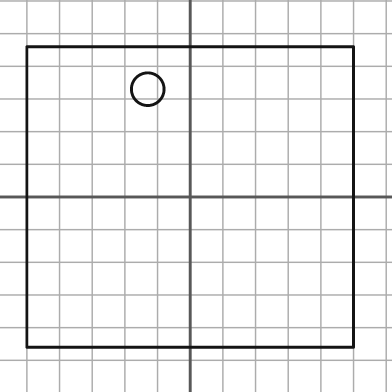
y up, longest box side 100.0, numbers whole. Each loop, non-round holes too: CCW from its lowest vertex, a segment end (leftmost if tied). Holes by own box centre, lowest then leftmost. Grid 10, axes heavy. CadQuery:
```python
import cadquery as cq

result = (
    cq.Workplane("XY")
    .moveTo(-50.0, -46.0)
    .lineTo(50.0, -46.0)
    .lineTo(50.0, 46.0)
    .lineTo(-50.0, 46.0)
    .close()
    .moveTo(-13.0, 33.0)
    .circle(5.0)
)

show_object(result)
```